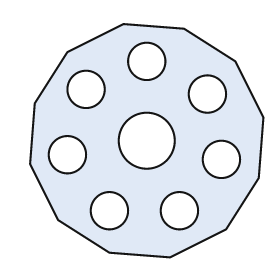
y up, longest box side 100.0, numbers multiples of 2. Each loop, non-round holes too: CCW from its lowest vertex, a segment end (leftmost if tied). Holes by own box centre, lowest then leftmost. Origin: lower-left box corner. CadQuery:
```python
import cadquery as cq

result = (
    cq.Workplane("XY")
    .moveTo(60.0, 0.0)
    .lineTo(84.0, 12.0)
    .lineTo(98.0, 34.0)
    .lineTo(100.0, 60.0)
    .lineTo(88.0, 84.0)
    .lineTo(66.0, 98.0)
    .lineTo(40.0, 100.0)
    .lineTo(16.0, 88.0)
    .lineTo(2.0, 66.0)
    .lineTo(0.0, 40.0)
    .lineTo(12.0, 16.0)
    .lineTo(34.0, 2.0)
    .close()
    .moveTo(34.0, 20.0)
    .circle(8.0)
    .moveTo(64.0, 20.0)
    .circle(8.0)
    .moveTo(82.0, 42.0)
    .circle(8.0)
    .moveTo(16.0, 44.0)
    .circle(8.0)
    .moveTo(50.0, 50.0)
    .circle(12.0)
    .moveTo(76.0, 70.0)
    .circle(8.0)
    .moveTo(24.0, 72.0)
    .circle(8.0)
    .moveTo(50.0, 84.0)
    .circle(8.0)
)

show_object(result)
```